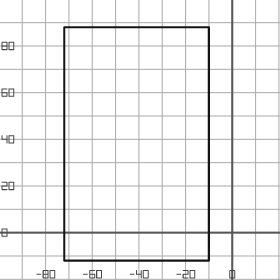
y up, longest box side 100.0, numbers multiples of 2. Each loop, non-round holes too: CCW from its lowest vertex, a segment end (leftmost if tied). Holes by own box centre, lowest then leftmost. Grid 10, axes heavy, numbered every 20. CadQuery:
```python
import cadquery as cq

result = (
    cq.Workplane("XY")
    .moveTo(-72.0, -12.0)
    .lineTo(-10.0, -12.0)
    .lineTo(-10.0, 88.0)
    .lineTo(-72.0, 88.0)
    .close()
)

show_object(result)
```